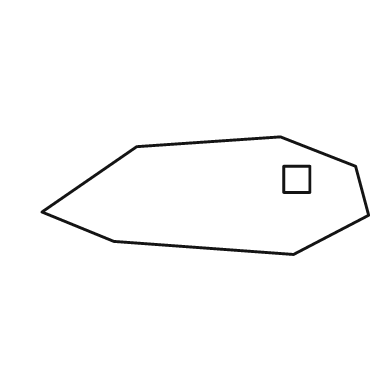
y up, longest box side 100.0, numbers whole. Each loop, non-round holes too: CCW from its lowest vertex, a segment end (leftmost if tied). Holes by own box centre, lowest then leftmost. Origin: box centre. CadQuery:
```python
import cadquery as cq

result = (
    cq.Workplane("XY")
    .moveTo(27.0, -18.0)
    .lineTo(50.0, -6.0)
    .lineTo(46.0, 9.0)
    .lineTo(23.0, 18.0)
    .lineTo(-21.0, 15.0)
    .lineTo(-50.0, -5.0)
    .lineTo(-28.0, -14.0)
    .close()
    .moveTo(24.0, 1.0)
    .lineTo(32.0, 1.0)
    .lineTo(32.0, 9.0)
    .lineTo(24.0, 9.0)
    .close()
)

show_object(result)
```